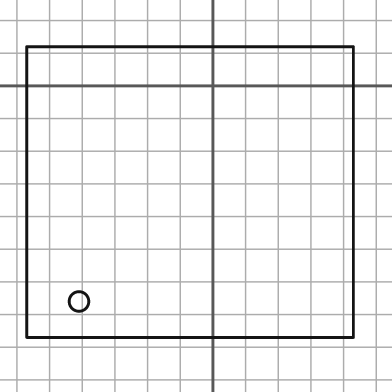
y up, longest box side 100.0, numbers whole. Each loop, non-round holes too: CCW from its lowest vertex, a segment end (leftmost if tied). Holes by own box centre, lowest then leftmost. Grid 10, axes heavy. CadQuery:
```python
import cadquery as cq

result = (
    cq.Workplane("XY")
    .moveTo(-57.0, -77.0)
    .lineTo(43.0, -77.0)
    .lineTo(43.0, 12.0)
    .lineTo(-57.0, 12.0)
    .close()
    .moveTo(-41.0, -66.0)
    .circle(3.0)
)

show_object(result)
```